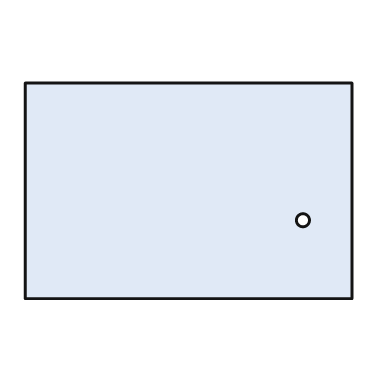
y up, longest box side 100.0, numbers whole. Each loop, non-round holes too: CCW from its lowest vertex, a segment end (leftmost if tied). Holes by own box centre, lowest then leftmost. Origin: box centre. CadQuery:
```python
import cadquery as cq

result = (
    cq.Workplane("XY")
    .moveTo(-50.0, -33.0)
    .lineTo(50.0, -33.0)
    .lineTo(50.0, 33.0)
    .lineTo(-50.0, 33.0)
    .close()
    .moveTo(35.0, -9.0)
    .circle(2.0)
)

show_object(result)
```